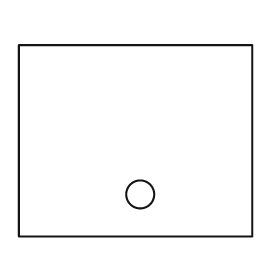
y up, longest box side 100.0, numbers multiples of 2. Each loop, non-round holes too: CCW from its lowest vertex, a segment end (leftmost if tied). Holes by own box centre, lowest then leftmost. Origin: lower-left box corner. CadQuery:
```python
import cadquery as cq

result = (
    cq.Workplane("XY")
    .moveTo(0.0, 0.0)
    .lineTo(100.0, 0.0)
    .lineTo(100.0, 82.0)
    .lineTo(0.0, 82.0)
    .close()
    .moveTo(52.0, 18.0)
    .circle(6.0)
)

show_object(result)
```